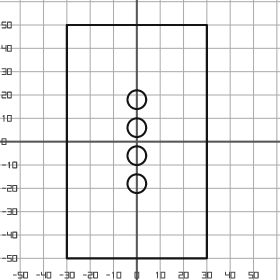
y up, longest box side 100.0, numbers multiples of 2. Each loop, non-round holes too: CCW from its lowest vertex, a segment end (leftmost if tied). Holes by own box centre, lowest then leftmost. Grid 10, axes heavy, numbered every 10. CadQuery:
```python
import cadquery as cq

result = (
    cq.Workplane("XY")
    .moveTo(-30.0, -50.0)
    .lineTo(30.0, -50.0)
    .lineTo(30.0, 50.0)
    .lineTo(-30.0, 50.0)
    .close()
    .moveTo(0.0, -18.0)
    .circle(4.0)
    .moveTo(0.0, -6.0)
    .circle(4.0)
    .moveTo(0.0, 6.0)
    .circle(4.0)
    .moveTo(0.0, 18.0)
    .circle(4.0)
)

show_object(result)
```